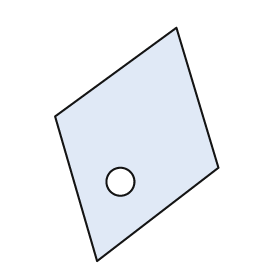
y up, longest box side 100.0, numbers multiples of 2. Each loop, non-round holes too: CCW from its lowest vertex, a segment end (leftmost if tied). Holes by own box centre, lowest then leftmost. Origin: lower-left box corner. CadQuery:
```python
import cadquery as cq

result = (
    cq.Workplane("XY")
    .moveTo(18.0, 0.0)
    .lineTo(70.0, 40.0)
    .lineTo(52.0, 100.0)
    .lineTo(0.0, 62.0)
    .close()
    .moveTo(28.0, 34.0)
    .circle(6.0)
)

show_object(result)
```